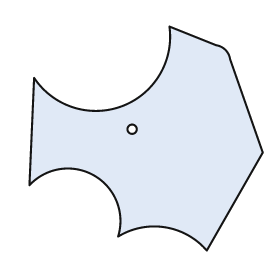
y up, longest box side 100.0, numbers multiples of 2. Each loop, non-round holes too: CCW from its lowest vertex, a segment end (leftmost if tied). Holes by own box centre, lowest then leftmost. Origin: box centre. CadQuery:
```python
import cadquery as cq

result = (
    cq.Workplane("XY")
    .moveTo(26.0, -48.0)
    .lineTo(50.0, -6.0)
    .lineTo(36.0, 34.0)
    .threePointArc((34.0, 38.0), (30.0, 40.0))
    .lineTo(10.0, 48.0)
    .threePointArc((-10.0, 14.0), (-48.0, 26.0))
    .lineTo(-50.0, -20.0)
    .threePointArc((-22.0, -16.0), (-12.0, -42.0))
    .threePointArc((8.0, -38.0), (26.0, -48.0))
    .close()
    .moveTo(-6.0, 4.0)
    .circle(2.0)
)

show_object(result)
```